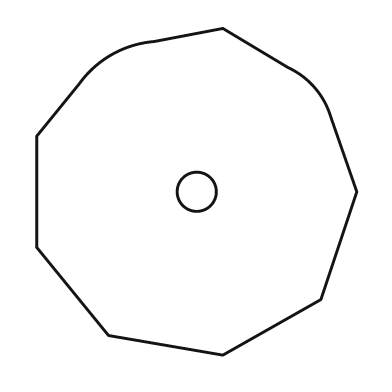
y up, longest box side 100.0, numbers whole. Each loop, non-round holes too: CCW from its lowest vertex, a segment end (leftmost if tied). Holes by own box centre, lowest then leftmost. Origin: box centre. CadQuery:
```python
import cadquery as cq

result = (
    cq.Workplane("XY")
    .moveTo(8.0, -50.0)
    .lineTo(38.0, -33.0)
    .lineTo(49.0, 0.0)
    .lineTo(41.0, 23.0)
    .threePointArc((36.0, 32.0), (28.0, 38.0))
    .lineTo(8.0, 50.0)
    .lineTo(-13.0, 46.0)
    .threePointArc((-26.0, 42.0), (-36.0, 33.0))
    .lineTo(-49.0, 17.0)
    .lineTo(-49.0, -17.0)
    .lineTo(-27.0, -44.0)
    .close()
    .moveTo(0.0, 0.0)
    .circle(6.0)
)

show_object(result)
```